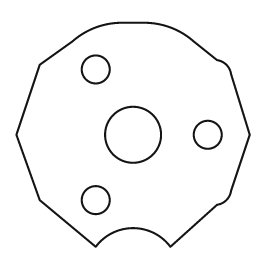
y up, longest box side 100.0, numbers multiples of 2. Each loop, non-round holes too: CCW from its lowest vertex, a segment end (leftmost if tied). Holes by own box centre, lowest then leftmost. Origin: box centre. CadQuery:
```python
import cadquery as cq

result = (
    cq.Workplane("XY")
    .moveTo(-16.0, -48.0)
    .threePointArc((0.0, -40.0), (16.0, -48.0))
    .lineTo(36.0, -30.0)
    .threePointArc((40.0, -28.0), (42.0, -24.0))
    .lineTo(50.0, 0.0)
    .lineTo(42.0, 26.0)
    .threePointArc((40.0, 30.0), (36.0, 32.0))
    .lineTo(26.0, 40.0)
    .threePointArc((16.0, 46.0), (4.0, 48.0))
    .lineTo(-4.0, 48.0)
    .threePointArc((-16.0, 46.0), (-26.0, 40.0))
    .lineTo(-40.0, 30.0)
    .lineTo(-50.0, 0.0)
    .lineTo(-40.0, -28.0)
    .close()
    .moveTo(-16.0, -28.0)
    .circle(6.0)
    .moveTo(0.0, 0.0)
    .circle(12.0)
    .moveTo(32.0, 0.0)
    .circle(6.0)
    .moveTo(-16.0, 28.0)
    .circle(6.0)
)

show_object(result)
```